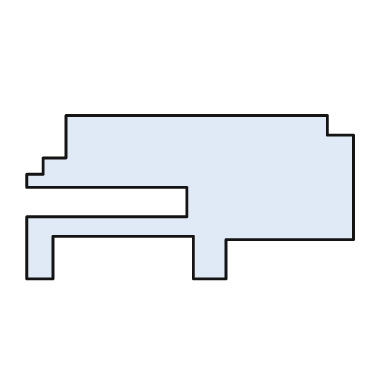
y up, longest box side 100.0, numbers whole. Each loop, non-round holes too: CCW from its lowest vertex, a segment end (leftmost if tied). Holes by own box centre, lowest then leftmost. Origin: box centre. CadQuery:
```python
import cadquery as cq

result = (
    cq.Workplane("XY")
    .moveTo(-50.0, -25.0)
    .lineTo(-42.0, -25.0)
    .lineTo(-42.0, -12.0)
    .lineTo(1.0, -12.0)
    .lineTo(1.0, -25.0)
    .lineTo(11.0, -25.0)
    .lineTo(11.0, -13.0)
    .lineTo(50.0, -13.0)
    .lineTo(50.0, 19.0)
    .lineTo(42.0, 19.0)
    .lineTo(42.0, 25.0)
    .lineTo(-38.0, 25.0)
    .lineTo(-38.0, 12.0)
    .lineTo(-45.0, 12.0)
    .lineTo(-45.0, 7.0)
    .lineTo(-50.0, 7.0)
    .lineTo(-50.0, 3.0)
    .lineTo(-1.0, 3.0)
    .lineTo(-1.0, -6.0)
    .lineTo(-50.0, -6.0)
    .close()
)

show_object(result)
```